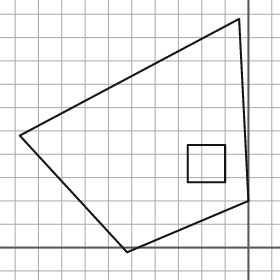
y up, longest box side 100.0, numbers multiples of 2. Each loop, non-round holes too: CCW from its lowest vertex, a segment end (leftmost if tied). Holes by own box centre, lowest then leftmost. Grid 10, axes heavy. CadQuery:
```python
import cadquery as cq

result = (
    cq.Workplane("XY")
    .moveTo(-52.0, -2.0)
    .lineTo(0.0, 20.0)
    .lineTo(-4.0, 98.0)
    .lineTo(-98.0, 48.0)
    .close()
    .moveTo(-26.0, 28.0)
    .lineTo(-10.0, 28.0)
    .lineTo(-10.0, 44.0)
    .lineTo(-26.0, 44.0)
    .close()
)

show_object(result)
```